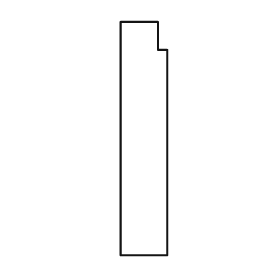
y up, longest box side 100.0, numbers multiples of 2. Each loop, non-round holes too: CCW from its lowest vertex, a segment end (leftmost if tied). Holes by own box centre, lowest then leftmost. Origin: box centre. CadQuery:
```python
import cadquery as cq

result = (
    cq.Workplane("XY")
    .moveTo(-10.0, -50.0)
    .lineTo(10.0, -50.0)
    .lineTo(10.0, 38.0)
    .lineTo(6.0, 38.0)
    .lineTo(6.0, 50.0)
    .lineTo(-10.0, 50.0)
    .close()
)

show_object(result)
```